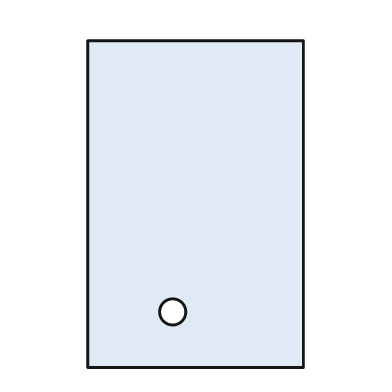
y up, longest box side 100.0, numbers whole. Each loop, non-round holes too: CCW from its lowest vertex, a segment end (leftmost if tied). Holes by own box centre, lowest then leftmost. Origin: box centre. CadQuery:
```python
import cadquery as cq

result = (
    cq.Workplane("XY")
    .moveTo(-33.0, -50.0)
    .lineTo(33.0, -50.0)
    .lineTo(33.0, 50.0)
    .lineTo(-33.0, 50.0)
    .close()
    .moveTo(-7.0, -33.0)
    .circle(4.0)
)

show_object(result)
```